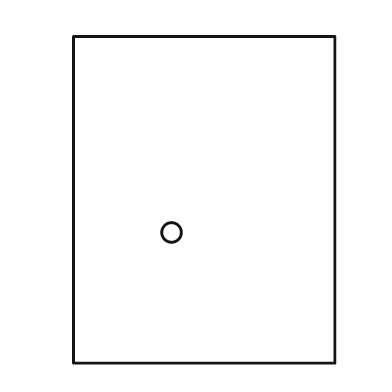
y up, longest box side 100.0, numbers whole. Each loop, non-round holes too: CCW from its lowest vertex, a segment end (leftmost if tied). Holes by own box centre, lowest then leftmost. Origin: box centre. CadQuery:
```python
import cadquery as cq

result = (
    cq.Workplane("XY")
    .moveTo(-40.0, -50.0)
    .lineTo(40.0, -50.0)
    .lineTo(40.0, 50.0)
    .lineTo(-40.0, 50.0)
    .close()
    .moveTo(-10.0, -10.0)
    .circle(3.0)
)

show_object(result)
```